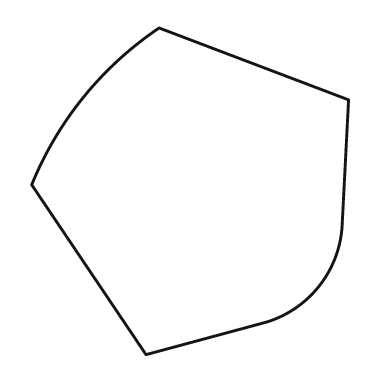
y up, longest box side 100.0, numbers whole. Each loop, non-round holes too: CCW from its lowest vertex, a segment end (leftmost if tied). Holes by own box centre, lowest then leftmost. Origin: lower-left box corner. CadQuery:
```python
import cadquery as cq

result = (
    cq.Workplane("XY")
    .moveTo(35.0, 0.0)
    .lineTo(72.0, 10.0)
    .threePointArc((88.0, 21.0), (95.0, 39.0))
    .lineTo(97.0, 78.0)
    .lineTo(39.0, 100.0)
    .threePointArc((16.0, 79.0), (0.0, 52.0))
    .close()
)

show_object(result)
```